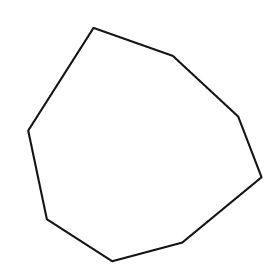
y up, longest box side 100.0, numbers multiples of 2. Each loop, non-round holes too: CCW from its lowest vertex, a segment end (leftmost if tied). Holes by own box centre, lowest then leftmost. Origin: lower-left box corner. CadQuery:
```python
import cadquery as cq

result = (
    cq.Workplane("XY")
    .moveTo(36.0, 0.0)
    .lineTo(66.0, 8.0)
    .lineTo(100.0, 36.0)
    .lineTo(90.0, 62.0)
    .lineTo(62.0, 88.0)
    .lineTo(28.0, 100.0)
    .lineTo(0.0, 56.0)
    .lineTo(8.0, 18.0)
    .close()
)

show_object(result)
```